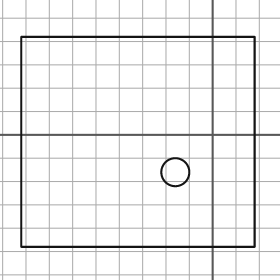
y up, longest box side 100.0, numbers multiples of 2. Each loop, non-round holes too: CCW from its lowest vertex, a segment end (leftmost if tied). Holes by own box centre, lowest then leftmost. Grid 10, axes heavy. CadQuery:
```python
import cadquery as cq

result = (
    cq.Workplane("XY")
    .moveTo(-82.0, -48.0)
    .lineTo(18.0, -48.0)
    .lineTo(18.0, 42.0)
    .lineTo(-82.0, 42.0)
    .close()
    .moveTo(-16.0, -16.0)
    .circle(6.0)
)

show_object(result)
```